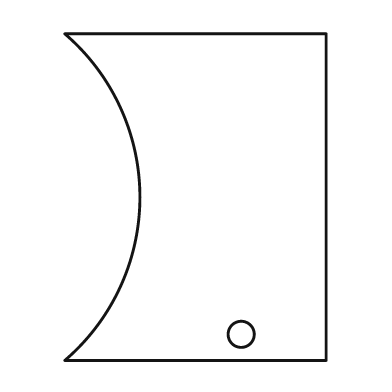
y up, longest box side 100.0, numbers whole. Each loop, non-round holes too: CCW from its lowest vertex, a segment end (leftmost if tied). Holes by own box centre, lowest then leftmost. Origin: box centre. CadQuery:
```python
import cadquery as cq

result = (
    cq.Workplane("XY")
    .moveTo(-40.0, -50.0)
    .lineTo(40.0, -50.0)
    .lineTo(40.0, 50.0)
    .lineTo(-40.0, 50.0)
    .threePointArc((-17.0, 0.0), (-40.0, -50.0))
    .close()
    .moveTo(14.0, -42.0)
    .circle(4.0)
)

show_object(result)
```